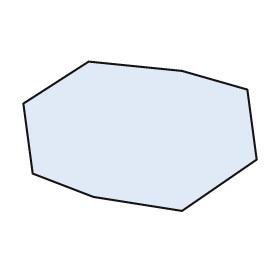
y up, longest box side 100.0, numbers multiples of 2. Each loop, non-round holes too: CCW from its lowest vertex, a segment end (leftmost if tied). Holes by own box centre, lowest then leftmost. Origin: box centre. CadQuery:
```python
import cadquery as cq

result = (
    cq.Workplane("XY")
    .moveTo(18.0, -32.0)
    .lineTo(50.0, -10.0)
    .lineTo(46.0, 20.0)
    .lineTo(18.0, 28.0)
    .lineTo(-22.0, 32.0)
    .lineTo(-50.0, 14.0)
    .lineTo(-46.0, -16.0)
    .lineTo(-20.0, -26.0)
    .close()
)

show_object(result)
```